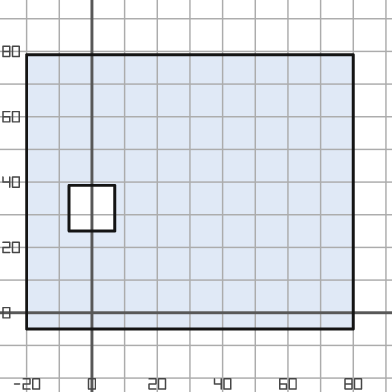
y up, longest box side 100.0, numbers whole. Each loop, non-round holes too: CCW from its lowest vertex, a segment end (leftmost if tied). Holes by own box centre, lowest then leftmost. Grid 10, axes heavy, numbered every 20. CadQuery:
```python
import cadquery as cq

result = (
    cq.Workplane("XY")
    .moveTo(-20.0, -5.0)
    .lineTo(80.0, -5.0)
    .lineTo(80.0, 79.0)
    .lineTo(-20.0, 79.0)
    .close()
    .moveTo(-7.0, 25.0)
    .lineTo(7.0, 25.0)
    .lineTo(7.0, 39.0)
    .lineTo(-7.0, 39.0)
    .close()
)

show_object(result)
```